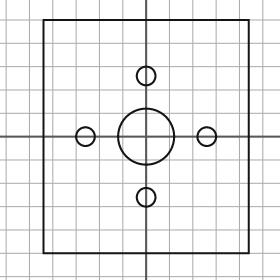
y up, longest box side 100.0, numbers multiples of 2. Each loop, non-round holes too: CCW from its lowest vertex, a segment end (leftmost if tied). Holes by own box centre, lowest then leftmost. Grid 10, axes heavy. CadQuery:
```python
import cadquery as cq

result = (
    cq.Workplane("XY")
    .moveTo(-44.0, -50.0)
    .lineTo(44.0, -50.0)
    .lineTo(44.0, 50.0)
    .lineTo(-44.0, 50.0)
    .close()
    .moveTo(0.0, -26.0)
    .circle(4.0)
    .moveTo(-26.0, 0.0)
    .circle(4.0)
    .moveTo(0.0, 0.0)
    .circle(12.0)
    .moveTo(26.0, 0.0)
    .circle(4.0)
    .moveTo(0.0, 26.0)
    .circle(4.0)
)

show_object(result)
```